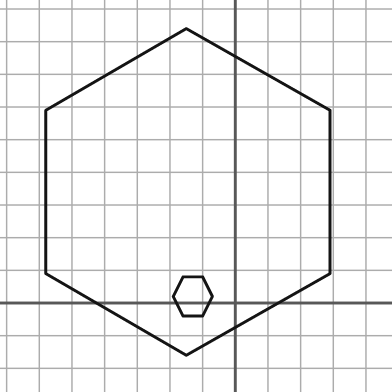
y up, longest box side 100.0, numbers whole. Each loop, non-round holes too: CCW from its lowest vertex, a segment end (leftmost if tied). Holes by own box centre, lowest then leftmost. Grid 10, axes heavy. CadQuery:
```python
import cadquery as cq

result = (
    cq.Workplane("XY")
    .moveTo(-15.0, -16.0)
    .lineTo(29.0, 9.0)
    .lineTo(29.0, 59.0)
    .lineTo(-15.0, 84.0)
    .lineTo(-58.0, 59.0)
    .lineTo(-58.0, 9.0)
    .close()
    .moveTo(-16.0, -4.0)
    .lineTo(-10.0, -4.0)
    .lineTo(-7.0, 2.0)
    .lineTo(-10.0, 8.0)
    .lineTo(-16.0, 8.0)
    .lineTo(-19.0, 2.0)
    .close()
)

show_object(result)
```